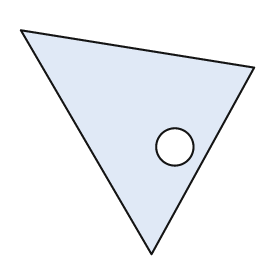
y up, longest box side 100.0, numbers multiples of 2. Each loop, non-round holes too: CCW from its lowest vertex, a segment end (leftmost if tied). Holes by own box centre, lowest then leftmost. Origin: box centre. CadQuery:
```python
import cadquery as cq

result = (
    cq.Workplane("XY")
    .moveTo(6.0, -48.0)
    .lineTo(50.0, 32.0)
    .lineTo(-50.0, 48.0)
    .close()
    .moveTo(16.0, -2.0)
    .circle(8.0)
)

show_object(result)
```